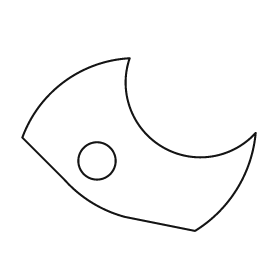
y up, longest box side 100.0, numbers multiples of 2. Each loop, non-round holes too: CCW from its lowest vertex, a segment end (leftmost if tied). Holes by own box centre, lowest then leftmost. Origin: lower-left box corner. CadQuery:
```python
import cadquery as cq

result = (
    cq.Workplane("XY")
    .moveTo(74.0, 0.0)
    .threePointArc((92.0, 18.0), (100.0, 42.0))
    .threePointArc((60.0, 36.0), (46.0, 74.0))
    .threePointArc((18.0, 64.0), (0.0, 40.0))
    .lineTo(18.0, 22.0)
    .threePointArc((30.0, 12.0), (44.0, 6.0))
    .close()
    .moveTo(32.0, 30.0)
    .circle(8.0)
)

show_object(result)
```